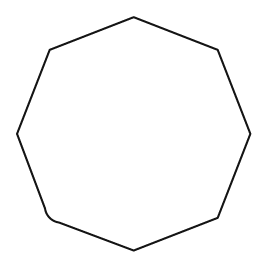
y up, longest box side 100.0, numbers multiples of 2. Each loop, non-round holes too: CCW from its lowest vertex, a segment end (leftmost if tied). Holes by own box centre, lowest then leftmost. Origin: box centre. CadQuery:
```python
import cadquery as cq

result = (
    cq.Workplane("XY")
    .moveTo(0.0, -50.0)
    .lineTo(36.0, -36.0)
    .lineTo(50.0, 0.0)
    .lineTo(36.0, 36.0)
    .lineTo(0.0, 50.0)
    .lineTo(-36.0, 36.0)
    .lineTo(-50.0, 0.0)
    .lineTo(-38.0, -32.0)
    .threePointArc((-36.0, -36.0), (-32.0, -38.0))
    .close()
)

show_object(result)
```